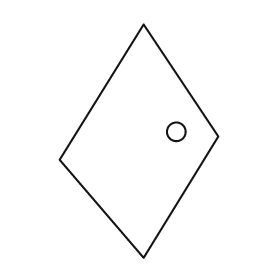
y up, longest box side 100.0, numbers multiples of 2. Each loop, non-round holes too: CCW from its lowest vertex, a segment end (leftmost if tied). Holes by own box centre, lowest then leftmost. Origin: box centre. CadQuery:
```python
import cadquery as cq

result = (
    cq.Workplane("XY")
    .moveTo(2.0, -50.0)
    .lineTo(34.0, 2.0)
    .lineTo(2.0, 50.0)
    .lineTo(-34.0, -8.0)
    .close()
    .moveTo(16.0, 4.0)
    .circle(4.0)
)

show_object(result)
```